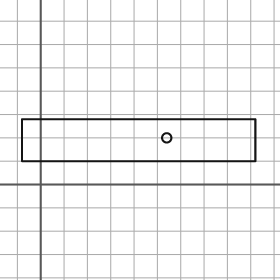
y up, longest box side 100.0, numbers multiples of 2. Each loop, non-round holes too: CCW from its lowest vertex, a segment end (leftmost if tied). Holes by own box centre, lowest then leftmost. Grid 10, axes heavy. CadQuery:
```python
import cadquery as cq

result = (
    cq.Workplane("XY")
    .moveTo(-8.0, 10.0)
    .lineTo(92.0, 10.0)
    .lineTo(92.0, 28.0)
    .lineTo(-8.0, 28.0)
    .close()
    .moveTo(54.0, 20.0)
    .circle(2.0)
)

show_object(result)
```